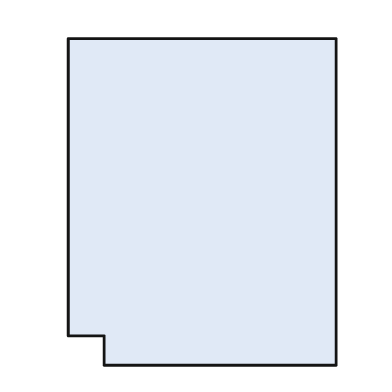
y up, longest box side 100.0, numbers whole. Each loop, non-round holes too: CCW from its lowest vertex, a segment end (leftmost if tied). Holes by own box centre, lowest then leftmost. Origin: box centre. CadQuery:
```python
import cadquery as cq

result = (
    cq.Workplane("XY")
    .moveTo(-30.0, -50.0)
    .lineTo(41.0, -50.0)
    .lineTo(41.0, 50.0)
    .lineTo(-41.0, 50.0)
    .lineTo(-41.0, -41.0)
    .lineTo(-30.0, -41.0)
    .close()
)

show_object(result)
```